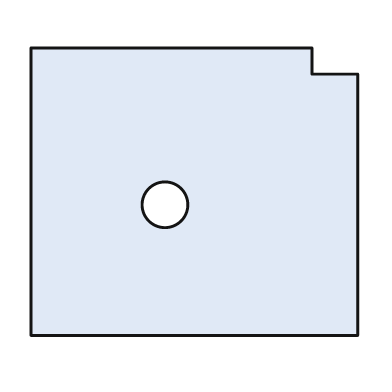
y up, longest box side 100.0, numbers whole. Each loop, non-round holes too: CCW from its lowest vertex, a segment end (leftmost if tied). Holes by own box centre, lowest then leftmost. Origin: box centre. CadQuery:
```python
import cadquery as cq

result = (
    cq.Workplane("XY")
    .moveTo(-50.0, -44.0)
    .lineTo(50.0, -44.0)
    .lineTo(50.0, 36.0)
    .lineTo(36.0, 36.0)
    .lineTo(36.0, 44.0)
    .lineTo(-50.0, 44.0)
    .close()
    .moveTo(-9.0, -4.0)
    .circle(7.0)
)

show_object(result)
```